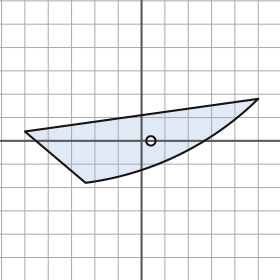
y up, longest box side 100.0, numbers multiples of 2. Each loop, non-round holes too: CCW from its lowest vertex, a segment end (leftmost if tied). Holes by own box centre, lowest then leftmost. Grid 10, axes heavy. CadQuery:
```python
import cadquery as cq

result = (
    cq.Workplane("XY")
    .moveTo(-24.0, -18.0)
    .threePointArc((16.0, -6.0), (50.0, 18.0))
    .lineTo(-50.0, 4.0)
    .close()
    .moveTo(4.0, 0.0)
    .circle(2.0)
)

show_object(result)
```